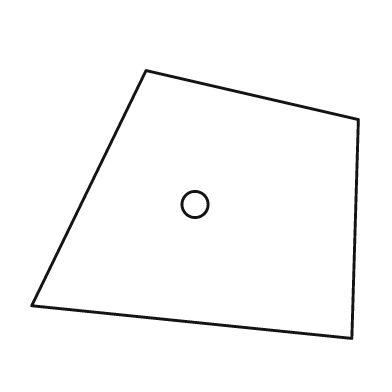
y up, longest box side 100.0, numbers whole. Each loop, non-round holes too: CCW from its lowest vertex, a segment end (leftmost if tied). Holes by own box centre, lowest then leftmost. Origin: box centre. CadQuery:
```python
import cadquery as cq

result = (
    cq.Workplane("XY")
    .moveTo(48.0, -41.0)
    .lineTo(50.0, 26.0)
    .lineTo(-15.0, 41.0)
    .lineTo(-50.0, -31.0)
    .close()
    .moveTo(0.0, 0.0)
    .circle(4.0)
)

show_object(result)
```